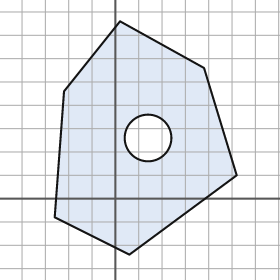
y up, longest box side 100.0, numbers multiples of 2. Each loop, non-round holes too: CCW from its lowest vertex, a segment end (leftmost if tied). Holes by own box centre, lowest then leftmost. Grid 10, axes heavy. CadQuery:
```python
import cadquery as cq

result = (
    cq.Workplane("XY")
    .moveTo(6.0, -24.0)
    .lineTo(52.0, 10.0)
    .lineTo(38.0, 56.0)
    .lineTo(2.0, 76.0)
    .lineTo(-22.0, 46.0)
    .lineTo(-26.0, -8.0)
    .close()
    .moveTo(14.0, 26.0)
    .circle(10.0)
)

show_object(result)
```